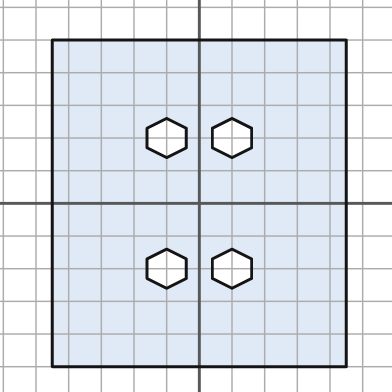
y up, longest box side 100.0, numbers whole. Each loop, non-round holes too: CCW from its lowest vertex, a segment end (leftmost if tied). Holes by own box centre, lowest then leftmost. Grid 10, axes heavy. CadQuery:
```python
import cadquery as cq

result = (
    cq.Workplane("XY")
    .moveTo(-45.0, -50.0)
    .lineTo(45.0, -50.0)
    .lineTo(45.0, 50.0)
    .lineTo(-45.0, 50.0)
    .close()
    .moveTo(-10.0, -26.0)
    .lineTo(-4.0, -23.0)
    .lineTo(-4.0, -17.0)
    .lineTo(-10.0, -14.0)
    .lineTo(-16.0, -17.0)
    .lineTo(-16.0, -23.0)
    .close()
    .moveTo(10.0, -26.0)
    .lineTo(16.0, -23.0)
    .lineTo(16.0, -17.0)
    .lineTo(10.0, -14.0)
    .lineTo(4.0, -17.0)
    .lineTo(4.0, -23.0)
    .close()
    .moveTo(-10.0, 14.0)
    .lineTo(-4.0, 17.0)
    .lineTo(-4.0, 23.0)
    .lineTo(-10.0, 26.0)
    .lineTo(-16.0, 23.0)
    .lineTo(-16.0, 17.0)
    .close()
    .moveTo(10.0, 14.0)
    .lineTo(16.0, 17.0)
    .lineTo(16.0, 23.0)
    .lineTo(10.0, 26.0)
    .lineTo(4.0, 23.0)
    .lineTo(4.0, 17.0)
    .close()
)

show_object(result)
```